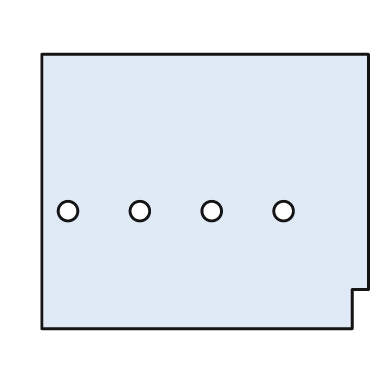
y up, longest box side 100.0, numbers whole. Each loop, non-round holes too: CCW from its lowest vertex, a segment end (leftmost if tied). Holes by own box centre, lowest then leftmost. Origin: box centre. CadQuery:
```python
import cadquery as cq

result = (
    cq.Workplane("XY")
    .moveTo(-50.0, -42.0)
    .lineTo(45.0, -42.0)
    .lineTo(45.0, -30.0)
    .lineTo(50.0, -30.0)
    .lineTo(50.0, 42.0)
    .lineTo(-50.0, 42.0)
    .close()
    .moveTo(-42.0, -6.0)
    .circle(3.0)
    .moveTo(-20.0, -6.0)
    .circle(3.0)
    .moveTo(2.0, -6.0)
    .circle(3.0)
    .moveTo(24.0, -6.0)
    .circle(3.0)
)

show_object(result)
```